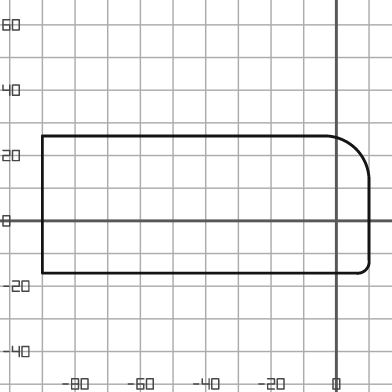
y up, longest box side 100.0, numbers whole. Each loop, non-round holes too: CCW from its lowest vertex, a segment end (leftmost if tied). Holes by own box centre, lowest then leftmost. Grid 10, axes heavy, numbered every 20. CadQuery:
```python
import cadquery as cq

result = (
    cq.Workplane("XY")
    .moveTo(-90.0, -16.0)
    .lineTo(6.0, -16.0)
    .threePointArc((9.0, -15.0), (10.0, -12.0))
    .lineTo(10.0, 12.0)
    .threePointArc((6.0, 22.0), (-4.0, 26.0))
    .lineTo(-90.0, 26.0)
    .close()
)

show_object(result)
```